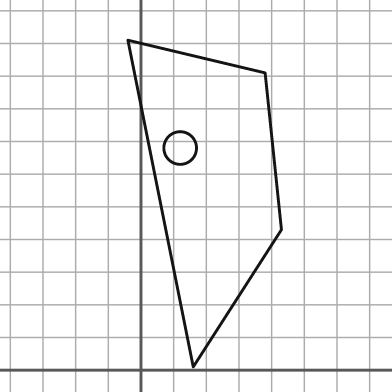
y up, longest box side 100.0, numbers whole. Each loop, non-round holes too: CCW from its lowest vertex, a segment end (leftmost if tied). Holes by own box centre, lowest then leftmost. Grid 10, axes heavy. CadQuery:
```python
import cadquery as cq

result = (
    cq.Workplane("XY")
    .moveTo(16.0, 1.0)
    .lineTo(43.0, 43.0)
    .lineTo(38.0, 91.0)
    .lineTo(-4.0, 101.0)
    .close()
    .moveTo(12.0, 68.0)
    .circle(5.0)
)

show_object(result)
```